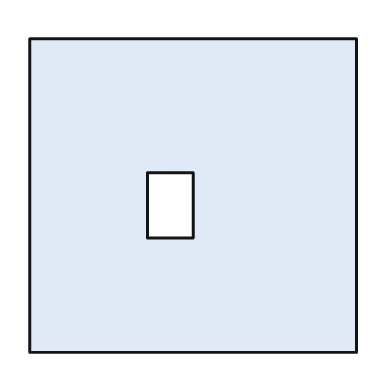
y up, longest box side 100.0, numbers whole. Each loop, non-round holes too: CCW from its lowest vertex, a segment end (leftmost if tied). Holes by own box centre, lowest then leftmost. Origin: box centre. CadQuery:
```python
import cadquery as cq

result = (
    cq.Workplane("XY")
    .moveTo(-50.0, -48.0)
    .lineTo(50.0, -48.0)
    .lineTo(50.0, 48.0)
    .lineTo(-50.0, 48.0)
    .close()
    .moveTo(-14.0, -13.0)
    .lineTo(0.0, -13.0)
    .lineTo(0.0, 7.0)
    .lineTo(-14.0, 7.0)
    .close()
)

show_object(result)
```